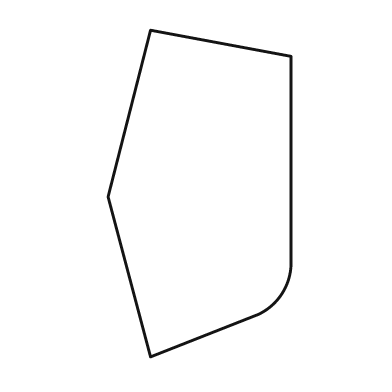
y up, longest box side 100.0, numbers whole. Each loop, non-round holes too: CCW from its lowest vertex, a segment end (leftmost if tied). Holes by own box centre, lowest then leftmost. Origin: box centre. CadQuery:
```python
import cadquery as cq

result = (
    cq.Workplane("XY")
    .moveTo(-15.0, -50.0)
    .lineTo(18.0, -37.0)
    .threePointArc((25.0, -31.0), (28.0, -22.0))
    .lineTo(28.0, 42.0)
    .lineTo(-15.0, 50.0)
    .lineTo(-28.0, -1.0)
    .close()
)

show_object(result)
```